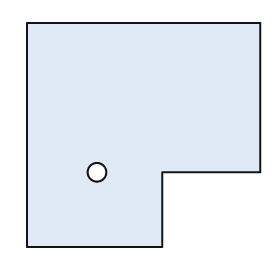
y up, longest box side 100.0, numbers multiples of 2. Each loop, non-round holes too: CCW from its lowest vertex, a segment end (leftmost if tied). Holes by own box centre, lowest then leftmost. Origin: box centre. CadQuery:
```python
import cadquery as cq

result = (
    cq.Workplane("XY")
    .moveTo(-50.0, -48.0)
    .lineTo(8.0, -48.0)
    .lineTo(8.0, -16.0)
    .lineTo(50.0, -16.0)
    .lineTo(50.0, 48.0)
    .lineTo(-50.0, 48.0)
    .close()
    .moveTo(-20.0, -16.0)
    .circle(4.0)
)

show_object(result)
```